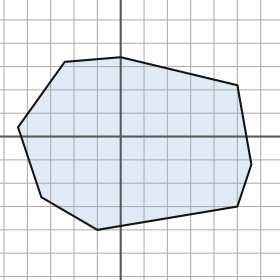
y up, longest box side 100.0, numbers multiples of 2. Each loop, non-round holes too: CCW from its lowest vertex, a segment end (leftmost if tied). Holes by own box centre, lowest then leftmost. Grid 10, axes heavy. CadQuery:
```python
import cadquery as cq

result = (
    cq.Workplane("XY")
    .moveTo(-10.0, -40.0)
    .lineTo(50.0, -30.0)
    .lineTo(56.0, -12.0)
    .lineTo(50.0, 22.0)
    .lineTo(0.0, 34.0)
    .lineTo(-24.0, 32.0)
    .lineTo(-44.0, 4.0)
    .lineTo(-34.0, -26.0)
    .close()
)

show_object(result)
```